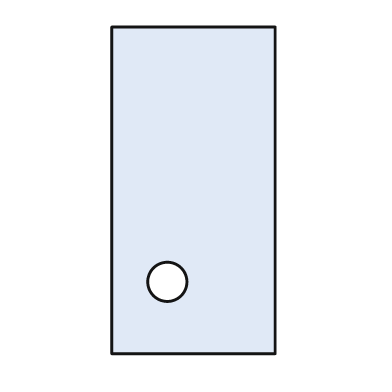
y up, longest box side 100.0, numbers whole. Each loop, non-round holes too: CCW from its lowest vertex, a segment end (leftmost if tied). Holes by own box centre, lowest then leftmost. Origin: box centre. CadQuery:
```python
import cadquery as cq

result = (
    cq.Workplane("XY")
    .moveTo(-25.0, -50.0)
    .lineTo(25.0, -50.0)
    .lineTo(25.0, 50.0)
    .lineTo(-25.0, 50.0)
    .close()
    .moveTo(-8.0, -28.0)
    .circle(6.0)
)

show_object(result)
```